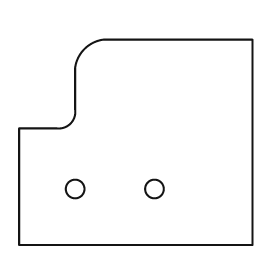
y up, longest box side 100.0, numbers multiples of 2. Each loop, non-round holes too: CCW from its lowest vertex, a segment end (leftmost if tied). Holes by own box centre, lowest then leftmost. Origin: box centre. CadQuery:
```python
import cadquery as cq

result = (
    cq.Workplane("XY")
    .moveTo(-50.0, -44.0)
    .lineTo(50.0, -44.0)
    .lineTo(50.0, 44.0)
    .lineTo(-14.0, 44.0)
    .threePointArc((-22.0, 40.0), (-26.0, 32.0))
    .lineTo(-26.0, 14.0)
    .threePointArc((-28.0, 8.0), (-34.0, 6.0))
    .lineTo(-50.0, 6.0)
    .close()
    .moveTo(-26.0, -20.0)
    .circle(4.0)
    .moveTo(8.0, -20.0)
    .circle(4.0)
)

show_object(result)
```